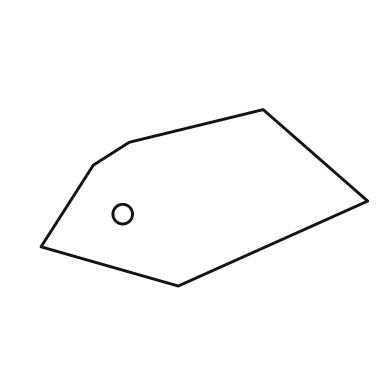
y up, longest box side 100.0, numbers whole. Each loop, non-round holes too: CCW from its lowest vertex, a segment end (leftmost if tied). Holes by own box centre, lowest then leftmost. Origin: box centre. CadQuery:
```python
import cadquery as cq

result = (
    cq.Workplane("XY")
    .moveTo(-8.0, -27.0)
    .lineTo(50.0, -1.0)
    .lineTo(18.0, 27.0)
    .lineTo(-23.0, 17.0)
    .lineTo(-34.0, 10.0)
    .lineTo(-50.0, -15.0)
    .close()
    .moveTo(-25.0, -5.0)
    .circle(3.0)
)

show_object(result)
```